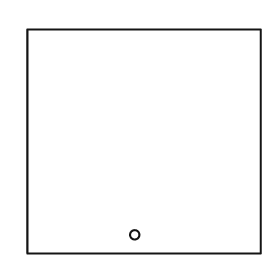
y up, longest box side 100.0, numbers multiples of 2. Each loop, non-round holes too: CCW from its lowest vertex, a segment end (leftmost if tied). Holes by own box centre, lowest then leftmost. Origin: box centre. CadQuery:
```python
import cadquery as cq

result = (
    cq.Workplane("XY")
    .moveTo(-50.0, -48.0)
    .lineTo(50.0, -48.0)
    .lineTo(50.0, 48.0)
    .lineTo(-50.0, 48.0)
    .close()
    .moveTo(-4.0, -40.0)
    .circle(2.0)
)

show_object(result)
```